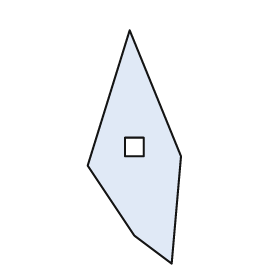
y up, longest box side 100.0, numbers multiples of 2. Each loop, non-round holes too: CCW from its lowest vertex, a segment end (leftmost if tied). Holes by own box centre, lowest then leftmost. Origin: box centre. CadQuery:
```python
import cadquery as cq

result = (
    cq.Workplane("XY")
    .moveTo(16.0, -50.0)
    .lineTo(20.0, -4.0)
    .lineTo(-2.0, 50.0)
    .lineTo(-20.0, -8.0)
    .lineTo(0.0, -38.0)
    .close()
    .moveTo(-4.0, -4.0)
    .lineTo(4.0, -4.0)
    .lineTo(4.0, 4.0)
    .lineTo(-4.0, 4.0)
    .close()
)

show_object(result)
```